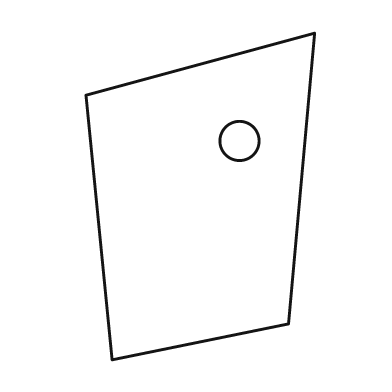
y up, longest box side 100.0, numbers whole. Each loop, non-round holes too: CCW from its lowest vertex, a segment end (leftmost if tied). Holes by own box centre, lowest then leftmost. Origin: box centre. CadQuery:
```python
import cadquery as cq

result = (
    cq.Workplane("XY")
    .moveTo(-27.0, -50.0)
    .lineTo(27.0, -39.0)
    .lineTo(35.0, 50.0)
    .lineTo(-35.0, 31.0)
    .close()
    .moveTo(12.0, 17.0)
    .circle(6.0)
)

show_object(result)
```